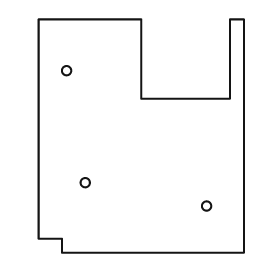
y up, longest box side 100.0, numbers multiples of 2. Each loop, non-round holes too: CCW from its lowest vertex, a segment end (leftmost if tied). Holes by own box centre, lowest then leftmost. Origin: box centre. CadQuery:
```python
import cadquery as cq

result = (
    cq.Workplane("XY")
    .moveTo(-34.0, -50.0)
    .lineTo(44.0, -50.0)
    .lineTo(44.0, 50.0)
    .lineTo(38.0, 50.0)
    .lineTo(38.0, 16.0)
    .lineTo(0.0, 16.0)
    .lineTo(0.0, 50.0)
    .lineTo(-44.0, 50.0)
    .lineTo(-44.0, -44.0)
    .lineTo(-34.0, -44.0)
    .close()
    .moveTo(28.0, -30.0)
    .circle(2.0)
    .moveTo(-24.0, -20.0)
    .circle(2.0)
    .moveTo(-32.0, 28.0)
    .circle(2.0)
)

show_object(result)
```